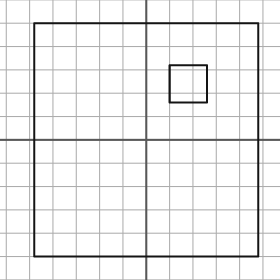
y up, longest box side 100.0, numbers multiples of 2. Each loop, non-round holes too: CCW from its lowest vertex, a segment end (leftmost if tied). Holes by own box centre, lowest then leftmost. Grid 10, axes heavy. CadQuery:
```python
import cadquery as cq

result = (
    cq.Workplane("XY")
    .moveTo(-48.0, -50.0)
    .lineTo(48.0, -50.0)
    .lineTo(48.0, 50.0)
    .lineTo(-48.0, 50.0)
    .close()
    .moveTo(10.0, 16.0)
    .lineTo(26.0, 16.0)
    .lineTo(26.0, 32.0)
    .lineTo(10.0, 32.0)
    .close()
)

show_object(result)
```